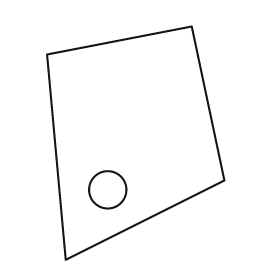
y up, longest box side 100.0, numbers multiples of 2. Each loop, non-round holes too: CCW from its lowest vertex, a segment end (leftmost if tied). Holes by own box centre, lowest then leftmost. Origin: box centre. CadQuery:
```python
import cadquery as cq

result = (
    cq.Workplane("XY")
    .moveTo(-30.0, -50.0)
    .lineTo(38.0, -16.0)
    .lineTo(24.0, 50.0)
    .lineTo(-38.0, 38.0)
    .close()
    .moveTo(-12.0, -20.0)
    .circle(8.0)
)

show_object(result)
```